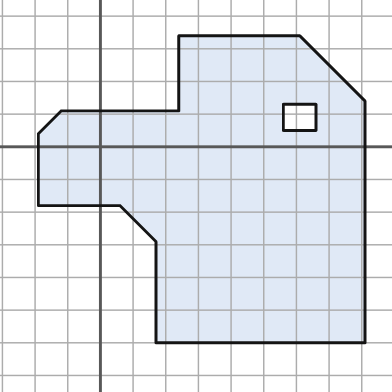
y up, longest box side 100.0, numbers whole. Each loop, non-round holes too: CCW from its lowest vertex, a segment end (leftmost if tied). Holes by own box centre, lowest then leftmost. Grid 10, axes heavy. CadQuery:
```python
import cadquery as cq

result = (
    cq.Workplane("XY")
    .moveTo(17.0, -60.0)
    .lineTo(81.0, -60.0)
    .lineTo(81.0, 14.0)
    .lineTo(61.0, 34.0)
    .lineTo(24.0, 34.0)
    .lineTo(24.0, 11.0)
    .lineTo(-12.0, 11.0)
    .lineTo(-19.0, 4.0)
    .lineTo(-19.0, -18.0)
    .lineTo(6.0, -18.0)
    .lineTo(17.0, -29.0)
    .close()
    .moveTo(56.0, 5.0)
    .lineTo(66.0, 5.0)
    .lineTo(66.0, 13.0)
    .lineTo(56.0, 13.0)
    .close()
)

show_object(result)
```